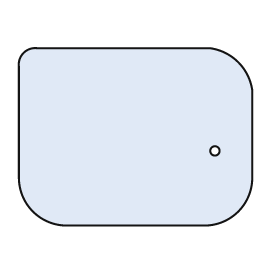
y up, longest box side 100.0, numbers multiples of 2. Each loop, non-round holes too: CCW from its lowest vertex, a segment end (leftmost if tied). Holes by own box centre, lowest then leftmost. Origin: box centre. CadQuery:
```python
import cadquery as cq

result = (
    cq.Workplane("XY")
    .moveTo(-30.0, -38.0)
    .lineTo(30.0, -38.0)
    .threePointArc((44.0, -32.0), (50.0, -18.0))
    .lineTo(50.0, 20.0)
    .threePointArc((44.0, 32.0), (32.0, 38.0))
    .lineTo(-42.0, 38.0)
    .threePointArc((-48.0, 36.0), (-50.0, 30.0))
    .lineTo(-50.0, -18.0)
    .threePointArc((-44.0, -32.0), (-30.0, -38.0))
    .close()
    .moveTo(34.0, -6.0)
    .circle(2.0)
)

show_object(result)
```